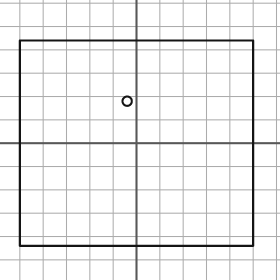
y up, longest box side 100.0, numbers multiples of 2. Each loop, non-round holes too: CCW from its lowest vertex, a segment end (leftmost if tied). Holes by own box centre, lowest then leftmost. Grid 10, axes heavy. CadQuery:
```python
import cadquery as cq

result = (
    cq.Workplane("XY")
    .moveTo(-50.0, -44.0)
    .lineTo(50.0, -44.0)
    .lineTo(50.0, 44.0)
    .lineTo(-50.0, 44.0)
    .close()
    .moveTo(-4.0, 18.0)
    .circle(2.0)
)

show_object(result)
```